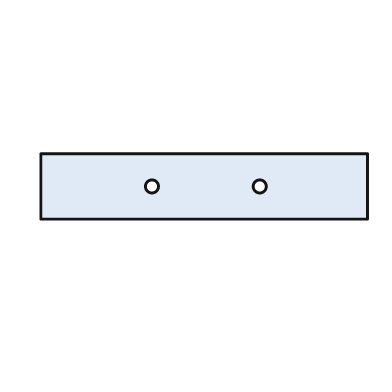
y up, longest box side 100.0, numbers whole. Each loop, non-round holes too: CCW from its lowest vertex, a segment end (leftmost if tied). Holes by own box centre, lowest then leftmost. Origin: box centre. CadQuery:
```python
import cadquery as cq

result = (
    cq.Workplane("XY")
    .moveTo(-50.0, -10.0)
    .lineTo(50.0, -10.0)
    .lineTo(50.0, 10.0)
    .lineTo(-50.0, 10.0)
    .close()
    .moveTo(-16.0, 0.0)
    .circle(2.0)
    .moveTo(17.0, 0.0)
    .circle(2.0)
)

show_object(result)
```